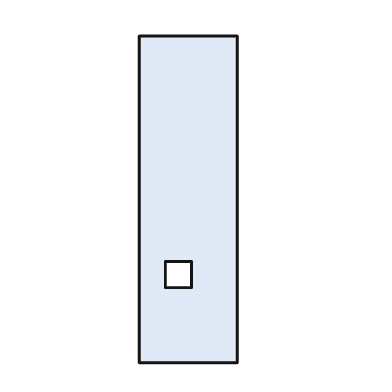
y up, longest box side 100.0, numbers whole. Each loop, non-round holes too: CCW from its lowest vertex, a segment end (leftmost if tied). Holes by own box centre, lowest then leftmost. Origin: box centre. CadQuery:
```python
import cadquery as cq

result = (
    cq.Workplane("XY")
    .moveTo(-15.0, -50.0)
    .lineTo(15.0, -50.0)
    .lineTo(15.0, 50.0)
    .lineTo(-15.0, 50.0)
    .close()
    .moveTo(-7.0, -27.0)
    .lineTo(1.0, -27.0)
    .lineTo(1.0, -19.0)
    .lineTo(-7.0, -19.0)
    .close()
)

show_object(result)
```